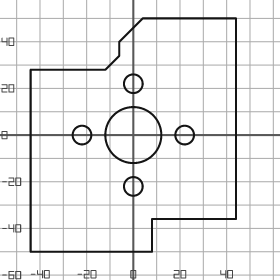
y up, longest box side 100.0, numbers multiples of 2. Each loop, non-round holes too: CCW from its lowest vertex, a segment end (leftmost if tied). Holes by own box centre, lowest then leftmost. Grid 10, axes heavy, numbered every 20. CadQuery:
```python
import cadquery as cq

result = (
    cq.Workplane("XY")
    .moveTo(-44.0, -50.0)
    .lineTo(8.0, -50.0)
    .lineTo(8.0, -36.0)
    .lineTo(44.0, -36.0)
    .lineTo(44.0, 50.0)
    .lineTo(4.0, 50.0)
    .lineTo(-6.0, 40.0)
    .lineTo(-6.0, 34.0)
    .lineTo(-12.0, 28.0)
    .lineTo(-44.0, 28.0)
    .close()
    .moveTo(0.0, -22.0)
    .circle(4.0)
    .moveTo(-22.0, 0.0)
    .circle(4.0)
    .moveTo(0.0, 0.0)
    .circle(12.0)
    .moveTo(22.0, 0.0)
    .circle(4.0)
    .moveTo(0.0, 22.0)
    .circle(4.0)
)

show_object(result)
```